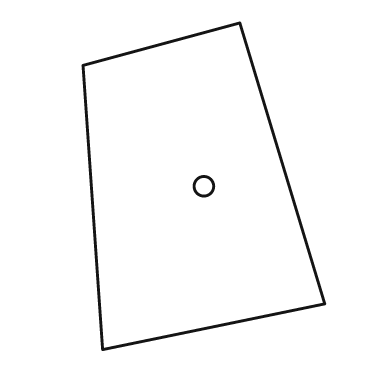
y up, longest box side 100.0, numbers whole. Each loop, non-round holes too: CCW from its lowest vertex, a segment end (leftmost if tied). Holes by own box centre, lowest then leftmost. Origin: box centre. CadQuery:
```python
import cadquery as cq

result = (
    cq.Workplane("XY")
    .moveTo(-31.0, -50.0)
    .lineTo(37.0, -36.0)
    .lineTo(11.0, 50.0)
    .lineTo(-37.0, 37.0)
    .close()
    .moveTo(0.0, 0.0)
    .circle(3.0)
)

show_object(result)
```